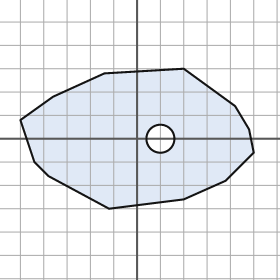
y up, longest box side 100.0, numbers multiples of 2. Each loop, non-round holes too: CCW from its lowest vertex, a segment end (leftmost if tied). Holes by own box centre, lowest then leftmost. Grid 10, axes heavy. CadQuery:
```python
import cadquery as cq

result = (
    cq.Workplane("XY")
    .moveTo(-12.0, -30.0)
    .lineTo(20.0, -26.0)
    .lineTo(38.0, -18.0)
    .lineTo(50.0, -6.0)
    .lineTo(48.0, 4.0)
    .lineTo(42.0, 14.0)
    .lineTo(20.0, 30.0)
    .lineTo(-14.0, 28.0)
    .lineTo(-36.0, 18.0)
    .lineTo(-50.0, 8.0)
    .lineTo(-44.0, -10.0)
    .lineTo(-38.0, -16.0)
    .close()
    .moveTo(10.0, 0.0)
    .circle(6.0)
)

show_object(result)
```